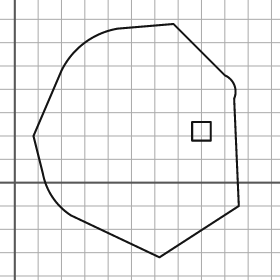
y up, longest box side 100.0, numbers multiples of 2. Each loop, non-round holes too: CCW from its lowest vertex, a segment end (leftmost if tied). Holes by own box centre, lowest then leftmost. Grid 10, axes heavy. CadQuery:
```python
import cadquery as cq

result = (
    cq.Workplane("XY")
    .moveTo(62.0, -32.0)
    .lineTo(96.0, -10.0)
    .lineTo(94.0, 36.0)
    .threePointArc((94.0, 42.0), (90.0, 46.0))
    .lineTo(68.0, 68.0)
    .lineTo(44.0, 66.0)
    .threePointArc((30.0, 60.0), (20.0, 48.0))
    .lineTo(8.0, 20.0)
    .lineTo(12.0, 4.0)
    .threePointArc((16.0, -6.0), (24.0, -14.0))
    .close()
    .moveTo(76.0, 18.0)
    .lineTo(84.0, 18.0)
    .lineTo(84.0, 26.0)
    .lineTo(76.0, 26.0)
    .close()
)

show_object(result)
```